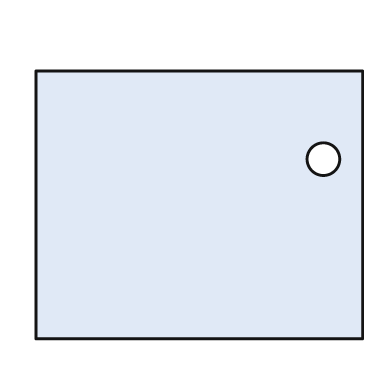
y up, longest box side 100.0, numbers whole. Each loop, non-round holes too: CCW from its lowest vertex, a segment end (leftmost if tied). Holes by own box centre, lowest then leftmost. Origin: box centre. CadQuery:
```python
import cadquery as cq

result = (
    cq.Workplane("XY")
    .moveTo(-50.0, -41.0)
    .lineTo(50.0, -41.0)
    .lineTo(50.0, 41.0)
    .lineTo(-50.0, 41.0)
    .close()
    .moveTo(38.0, 14.0)
    .circle(5.0)
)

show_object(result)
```